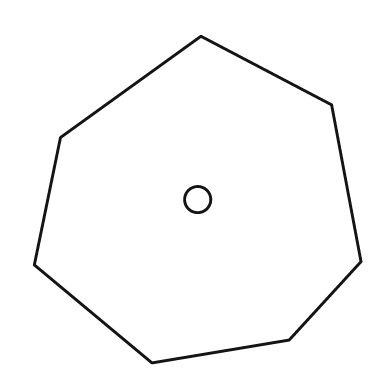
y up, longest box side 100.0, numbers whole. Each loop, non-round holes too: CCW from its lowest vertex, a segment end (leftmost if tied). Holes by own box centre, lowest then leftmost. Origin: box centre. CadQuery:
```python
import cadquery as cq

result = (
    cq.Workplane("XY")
    .moveTo(-14.0, -50.0)
    .lineTo(28.0, -43.0)
    .lineTo(50.0, -19.0)
    .lineTo(41.0, 29.0)
    .lineTo(1.0, 50.0)
    .lineTo(-42.0, 19.0)
    .lineTo(-50.0, -20.0)
    .close()
    .moveTo(0.0, 0.0)
    .circle(4.0)
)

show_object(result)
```